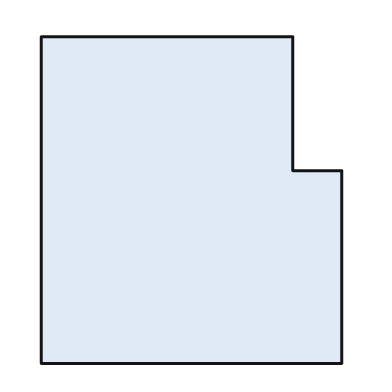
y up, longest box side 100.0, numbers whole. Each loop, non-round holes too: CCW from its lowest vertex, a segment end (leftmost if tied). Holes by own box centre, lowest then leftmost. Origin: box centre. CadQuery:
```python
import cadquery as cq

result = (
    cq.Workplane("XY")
    .moveTo(-46.0, -50.0)
    .lineTo(46.0, -50.0)
    .lineTo(46.0, 9.0)
    .lineTo(31.0, 9.0)
    .lineTo(31.0, 50.0)
    .lineTo(-46.0, 50.0)
    .close()
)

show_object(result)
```